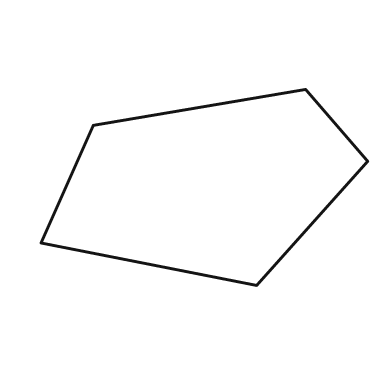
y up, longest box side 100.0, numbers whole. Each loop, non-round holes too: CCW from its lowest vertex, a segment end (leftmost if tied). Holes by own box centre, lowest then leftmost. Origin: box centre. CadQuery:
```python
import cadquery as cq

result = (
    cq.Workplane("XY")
    .moveTo(16.0, -30.0)
    .lineTo(50.0, 8.0)
    .lineTo(31.0, 30.0)
    .lineTo(-34.0, 19.0)
    .lineTo(-50.0, -17.0)
    .close()
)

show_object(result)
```